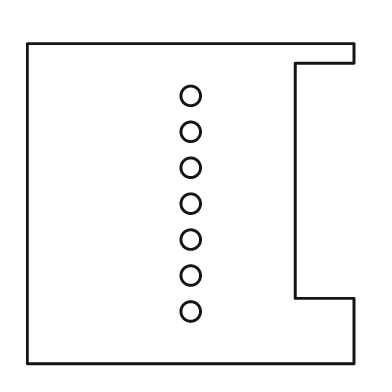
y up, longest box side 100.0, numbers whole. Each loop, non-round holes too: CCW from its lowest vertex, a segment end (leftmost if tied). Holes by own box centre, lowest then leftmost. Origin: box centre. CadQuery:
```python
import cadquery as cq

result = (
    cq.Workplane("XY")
    .moveTo(-50.0, -49.0)
    .lineTo(50.0, -49.0)
    .lineTo(50.0, -29.0)
    .lineTo(32.0, -29.0)
    .lineTo(32.0, 43.0)
    .lineTo(50.0, 43.0)
    .lineTo(50.0, 49.0)
    .lineTo(-50.0, 49.0)
    .close()
    .moveTo(0.0, -33.0)
    .circle(3.0)
    .moveTo(0.0, -22.0)
    .circle(3.0)
    .moveTo(0.0, -11.0)
    .circle(3.0)
    .moveTo(0.0, 0.0)
    .circle(3.0)
    .moveTo(0.0, 11.0)
    .circle(3.0)
    .moveTo(0.0, 22.0)
    .circle(3.0)
    .moveTo(0.0, 33.0)
    .circle(3.0)
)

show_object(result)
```